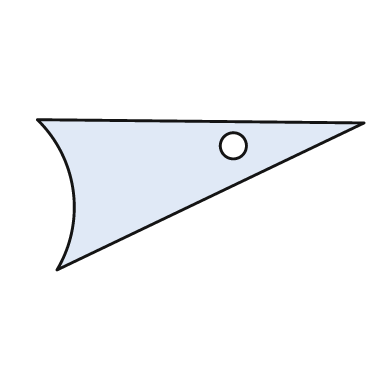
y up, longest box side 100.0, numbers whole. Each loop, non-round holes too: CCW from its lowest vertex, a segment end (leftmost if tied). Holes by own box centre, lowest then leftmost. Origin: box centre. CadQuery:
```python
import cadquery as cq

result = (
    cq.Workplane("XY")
    .moveTo(-44.0, -23.0)
    .lineTo(50.0, 22.0)
    .lineTo(-50.0, 23.0)
    .threePointArc((-39.0, 1.0), (-44.0, -23.0))
    .close()
    .moveTo(10.0, 15.0)
    .circle(4.0)
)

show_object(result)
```